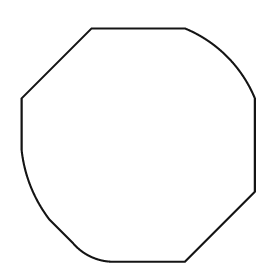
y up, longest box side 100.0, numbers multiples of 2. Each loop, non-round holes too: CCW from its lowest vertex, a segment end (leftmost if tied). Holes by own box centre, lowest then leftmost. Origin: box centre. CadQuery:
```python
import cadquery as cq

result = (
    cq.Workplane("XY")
    .moveTo(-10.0, -50.0)
    .lineTo(20.0, -50.0)
    .lineTo(50.0, -20.0)
    .lineTo(50.0, 20.0)
    .threePointArc((38.0, 38.0), (20.0, 50.0))
    .lineTo(-20.0, 50.0)
    .lineTo(-50.0, 20.0)
    .lineTo(-50.0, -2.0)
    .threePointArc((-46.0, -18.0), (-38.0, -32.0))
    .lineTo(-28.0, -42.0)
    .threePointArc((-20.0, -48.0), (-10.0, -50.0))
    .close()
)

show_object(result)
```